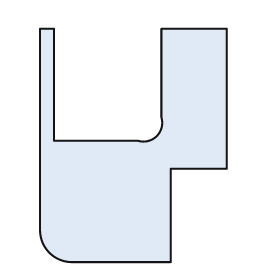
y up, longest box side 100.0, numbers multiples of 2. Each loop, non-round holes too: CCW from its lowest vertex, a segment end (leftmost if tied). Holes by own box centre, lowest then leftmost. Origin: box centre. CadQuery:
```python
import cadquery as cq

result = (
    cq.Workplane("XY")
    .moveTo(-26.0, -50.0)
    .lineTo(16.0, -50.0)
    .lineTo(16.0, -10.0)
    .lineTo(40.0, -10.0)
    .lineTo(40.0, 50.0)
    .lineTo(12.0, 50.0)
    .lineTo(12.0, 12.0)
    .threePointArc((10.0, 4.0), (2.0, 2.0))
    .lineTo(-34.0, 2.0)
    .lineTo(-34.0, 50.0)
    .lineTo(-40.0, 50.0)
    .lineTo(-40.0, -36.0)
    .threePointArc((-36.0, -46.0), (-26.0, -50.0))
    .close()
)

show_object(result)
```